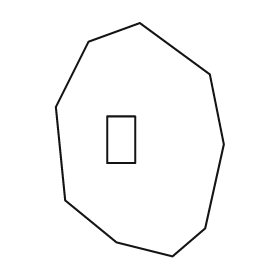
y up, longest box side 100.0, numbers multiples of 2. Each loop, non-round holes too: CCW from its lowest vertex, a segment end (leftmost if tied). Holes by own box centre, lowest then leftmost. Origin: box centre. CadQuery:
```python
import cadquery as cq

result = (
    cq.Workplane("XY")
    .moveTo(14.0, -50.0)
    .lineTo(28.0, -38.0)
    .lineTo(36.0, -2.0)
    .lineTo(30.0, 28.0)
    .lineTo(0.0, 50.0)
    .lineTo(-22.0, 42.0)
    .lineTo(-36.0, 14.0)
    .lineTo(-32.0, -26.0)
    .lineTo(-10.0, -44.0)
    .close()
    .moveTo(-14.0, -10.0)
    .lineTo(-2.0, -10.0)
    .lineTo(-2.0, 10.0)
    .lineTo(-14.0, 10.0)
    .close()
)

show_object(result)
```